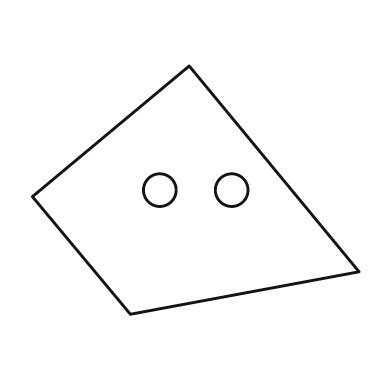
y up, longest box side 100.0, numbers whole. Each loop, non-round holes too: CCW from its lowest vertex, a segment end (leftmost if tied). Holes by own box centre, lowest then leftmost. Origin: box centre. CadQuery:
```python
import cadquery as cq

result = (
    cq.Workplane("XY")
    .moveTo(-20.0, -38.0)
    .lineTo(50.0, -25.0)
    .lineTo(-2.0, 38.0)
    .lineTo(-50.0, -2.0)
    .close()
    .moveTo(-11.0, 0.0)
    .circle(5.0)
    .moveTo(11.0, 0.0)
    .circle(5.0)
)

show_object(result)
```